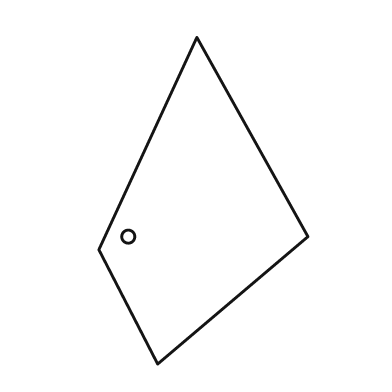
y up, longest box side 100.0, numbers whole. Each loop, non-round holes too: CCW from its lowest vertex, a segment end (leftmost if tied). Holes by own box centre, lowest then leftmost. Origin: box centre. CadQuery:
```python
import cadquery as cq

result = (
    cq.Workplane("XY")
    .moveTo(-14.0, -50.0)
    .lineTo(32.0, -11.0)
    .lineTo(-2.0, 50.0)
    .lineTo(-32.0, -15.0)
    .close()
    .moveTo(-23.0, -11.0)
    .circle(2.0)
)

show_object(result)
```